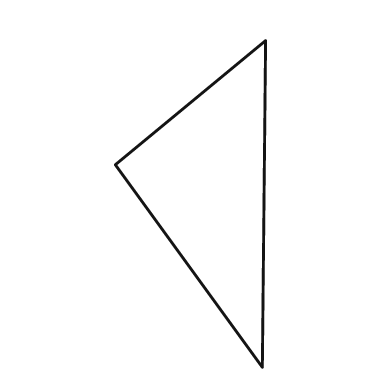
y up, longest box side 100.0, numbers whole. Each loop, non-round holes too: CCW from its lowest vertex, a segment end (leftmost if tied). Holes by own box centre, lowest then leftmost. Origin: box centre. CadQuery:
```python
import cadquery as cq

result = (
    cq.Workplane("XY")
    .moveTo(22.0, -50.0)
    .lineTo(23.0, 50.0)
    .lineTo(-23.0, 12.0)
    .close()
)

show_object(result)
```